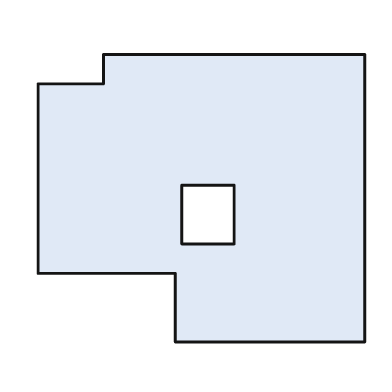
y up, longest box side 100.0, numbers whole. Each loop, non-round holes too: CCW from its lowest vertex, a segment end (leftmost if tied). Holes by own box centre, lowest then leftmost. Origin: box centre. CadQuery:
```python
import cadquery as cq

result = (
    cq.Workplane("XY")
    .moveTo(-8.0, -44.0)
    .lineTo(50.0, -44.0)
    .lineTo(50.0, 44.0)
    .lineTo(-30.0, 44.0)
    .lineTo(-30.0, 35.0)
    .lineTo(-50.0, 35.0)
    .lineTo(-50.0, -23.0)
    .lineTo(-8.0, -23.0)
    .close()
    .moveTo(-6.0, -14.0)
    .lineTo(10.0, -14.0)
    .lineTo(10.0, 4.0)
    .lineTo(-6.0, 4.0)
    .close()
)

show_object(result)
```